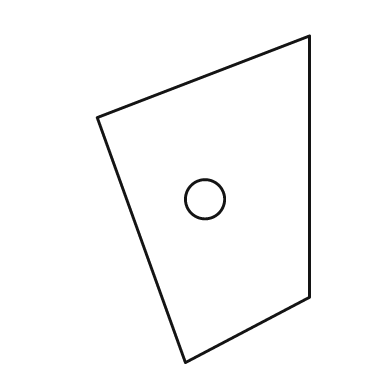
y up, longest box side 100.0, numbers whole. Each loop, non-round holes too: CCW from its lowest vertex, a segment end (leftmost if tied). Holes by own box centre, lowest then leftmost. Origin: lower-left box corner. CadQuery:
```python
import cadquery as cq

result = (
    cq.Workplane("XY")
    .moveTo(27.0, 0.0)
    .lineTo(65.0, 20.0)
    .lineTo(65.0, 100.0)
    .lineTo(0.0, 75.0)
    .close()
    .moveTo(33.0, 50.0)
    .circle(6.0)
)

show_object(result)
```